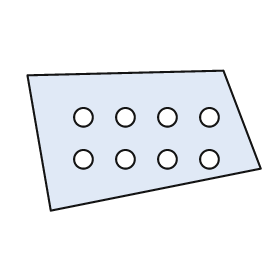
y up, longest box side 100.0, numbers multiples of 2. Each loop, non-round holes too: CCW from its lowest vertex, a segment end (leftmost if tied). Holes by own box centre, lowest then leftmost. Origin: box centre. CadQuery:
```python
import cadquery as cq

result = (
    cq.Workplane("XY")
    .moveTo(-40.0, -30.0)
    .lineTo(50.0, -12.0)
    .lineTo(34.0, 30.0)
    .lineTo(-50.0, 28.0)
    .close()
    .moveTo(-26.0, -8.0)
    .circle(4.0)
    .moveTo(-8.0, -8.0)
    .circle(4.0)
    .moveTo(10.0, -8.0)
    .circle(4.0)
    .moveTo(28.0, -8.0)
    .circle(4.0)
    .moveTo(-26.0, 10.0)
    .circle(4.0)
    .moveTo(-8.0, 10.0)
    .circle(4.0)
    .moveTo(10.0, 10.0)
    .circle(4.0)
    .moveTo(28.0, 10.0)
    .circle(4.0)
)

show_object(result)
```